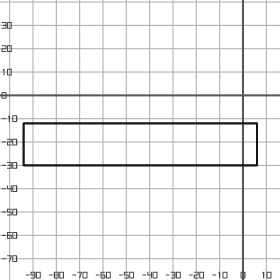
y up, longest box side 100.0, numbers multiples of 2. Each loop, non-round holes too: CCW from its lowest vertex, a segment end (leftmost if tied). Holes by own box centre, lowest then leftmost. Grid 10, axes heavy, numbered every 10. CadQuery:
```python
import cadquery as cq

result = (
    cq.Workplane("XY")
    .moveTo(-94.0, -30.0)
    .lineTo(6.0, -30.0)
    .lineTo(6.0, -12.0)
    .lineTo(-94.0, -12.0)
    .close()
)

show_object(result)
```